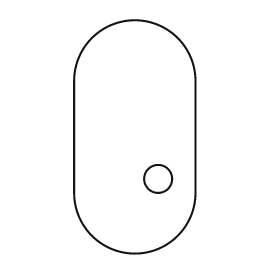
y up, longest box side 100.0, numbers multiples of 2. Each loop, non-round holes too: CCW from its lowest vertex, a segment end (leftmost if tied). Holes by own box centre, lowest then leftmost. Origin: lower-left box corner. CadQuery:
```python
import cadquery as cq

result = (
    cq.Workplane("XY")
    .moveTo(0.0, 26.0)
    .threePointArc((26.0, 0.0), (52.0, 26.0))
    .lineTo(52.0, 74.0)
    .threePointArc((26.0, 100.0), (0.0, 74.0))
    .close()
    .moveTo(36.0, 32.0)
    .circle(6.0)
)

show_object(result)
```